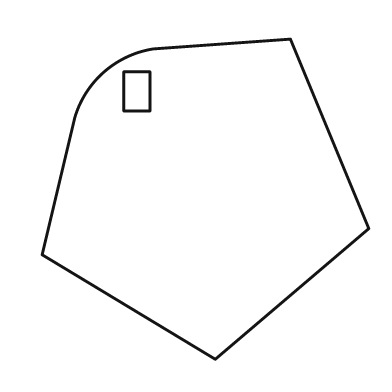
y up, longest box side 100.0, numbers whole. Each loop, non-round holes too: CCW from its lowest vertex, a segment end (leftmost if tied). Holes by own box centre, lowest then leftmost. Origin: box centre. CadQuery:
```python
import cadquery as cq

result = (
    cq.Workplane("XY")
    .moveTo(3.0, -49.0)
    .lineTo(50.0, -9.0)
    .lineTo(26.0, 49.0)
    .lineTo(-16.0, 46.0)
    .threePointArc((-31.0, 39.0), (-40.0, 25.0))
    .lineTo(-50.0, -17.0)
    .close()
    .moveTo(-25.0, 27.0)
    .lineTo(-17.0, 27.0)
    .lineTo(-17.0, 39.0)
    .lineTo(-25.0, 39.0)
    .close()
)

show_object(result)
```